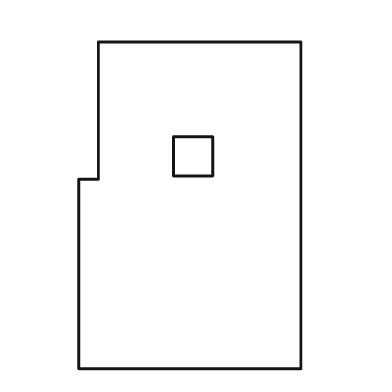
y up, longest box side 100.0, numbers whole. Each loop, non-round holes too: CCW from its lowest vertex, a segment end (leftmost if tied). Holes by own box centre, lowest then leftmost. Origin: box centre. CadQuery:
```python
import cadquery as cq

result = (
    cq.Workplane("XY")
    .moveTo(-34.0, -50.0)
    .lineTo(34.0, -50.0)
    .lineTo(34.0, 50.0)
    .lineTo(-28.0, 50.0)
    .lineTo(-28.0, 8.0)
    .lineTo(-34.0, 8.0)
    .close()
    .moveTo(-5.0, 9.0)
    .lineTo(7.0, 9.0)
    .lineTo(7.0, 21.0)
    .lineTo(-5.0, 21.0)
    .close()
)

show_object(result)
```